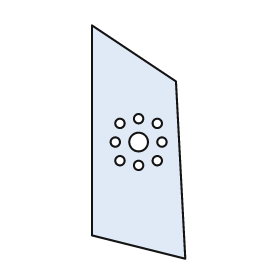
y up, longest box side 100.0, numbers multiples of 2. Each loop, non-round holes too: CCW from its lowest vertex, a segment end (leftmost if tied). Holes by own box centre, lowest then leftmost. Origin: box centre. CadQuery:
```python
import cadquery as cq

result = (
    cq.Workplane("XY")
    .moveTo(20.0, -50.0)
    .lineTo(16.0, 26.0)
    .lineTo(-20.0, 50.0)
    .lineTo(-20.0, -40.0)
    .close()
    .moveTo(0.0, -10.0)
    .circle(2.0)
    .moveTo(-8.0, -8.0)
    .circle(2.0)
    .moveTo(8.0, -8.0)
    .circle(2.0)
    .moveTo(-10.0, 0.0)
    .circle(2.0)
    .moveTo(0.0, 0.0)
    .circle(4.0)
    .moveTo(10.0, 0.0)
    .circle(2.0)
    .moveTo(-8.0, 8.0)
    .circle(2.0)
    .moveTo(8.0, 8.0)
    .circle(2.0)
    .moveTo(0.0, 10.0)
    .circle(2.0)
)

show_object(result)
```